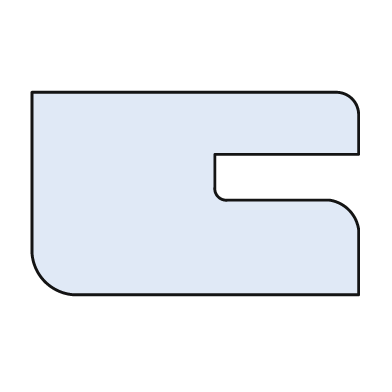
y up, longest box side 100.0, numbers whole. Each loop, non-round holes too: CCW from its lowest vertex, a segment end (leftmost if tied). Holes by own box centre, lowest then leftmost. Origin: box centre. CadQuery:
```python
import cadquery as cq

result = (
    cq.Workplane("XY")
    .moveTo(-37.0, -31.0)
    .lineTo(50.0, -31.0)
    .lineTo(50.0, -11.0)
    .threePointArc((47.0, -5.0), (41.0, -2.0))
    .lineTo(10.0, -2.0)
    .threePointArc((7.0, -1.0), (6.0, 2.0))
    .lineTo(6.0, 12.0)
    .lineTo(50.0, 12.0)
    .lineTo(50.0, 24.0)
    .threePointArc((48.0, 29.0), (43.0, 31.0))
    .lineTo(-50.0, 31.0)
    .lineTo(-50.0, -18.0)
    .threePointArc((-46.0, -27.0), (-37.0, -31.0))
    .close()
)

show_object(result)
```